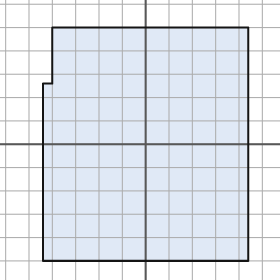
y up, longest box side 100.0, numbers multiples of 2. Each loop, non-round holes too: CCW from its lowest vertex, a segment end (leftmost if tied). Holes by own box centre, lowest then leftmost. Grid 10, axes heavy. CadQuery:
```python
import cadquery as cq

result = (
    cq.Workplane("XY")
    .moveTo(-44.0, -50.0)
    .lineTo(44.0, -50.0)
    .lineTo(44.0, 50.0)
    .lineTo(-40.0, 50.0)
    .lineTo(-40.0, 26.0)
    .lineTo(-44.0, 26.0)
    .close()
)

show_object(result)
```